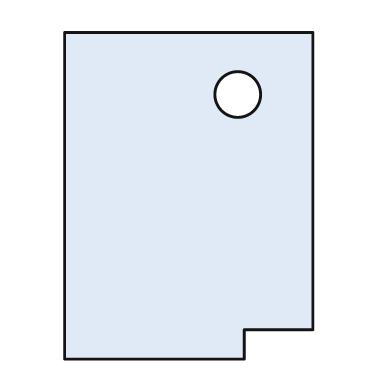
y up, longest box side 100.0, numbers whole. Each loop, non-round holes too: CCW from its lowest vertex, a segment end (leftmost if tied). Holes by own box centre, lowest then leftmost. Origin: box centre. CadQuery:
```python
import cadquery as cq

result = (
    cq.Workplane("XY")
    .moveTo(-38.0, -50.0)
    .lineTo(17.0, -50.0)
    .lineTo(17.0, -41.0)
    .lineTo(38.0, -41.0)
    .lineTo(38.0, 50.0)
    .lineTo(-38.0, 50.0)
    .close()
    .moveTo(15.0, 31.0)
    .circle(7.0)
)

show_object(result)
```